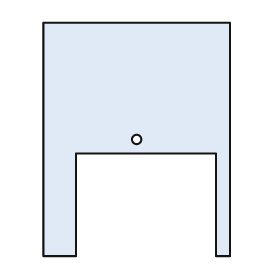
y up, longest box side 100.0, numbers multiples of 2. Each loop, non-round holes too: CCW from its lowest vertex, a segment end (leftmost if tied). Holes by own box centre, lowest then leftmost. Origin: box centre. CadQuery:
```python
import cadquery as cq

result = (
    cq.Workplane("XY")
    .moveTo(-40.0, -50.0)
    .lineTo(-26.0, -50.0)
    .lineTo(-26.0, -6.0)
    .lineTo(34.0, -6.0)
    .lineTo(34.0, -50.0)
    .lineTo(40.0, -50.0)
    .lineTo(40.0, 50.0)
    .lineTo(-40.0, 50.0)
    .close()
    .moveTo(0.0, 0.0)
    .circle(2.0)
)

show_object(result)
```